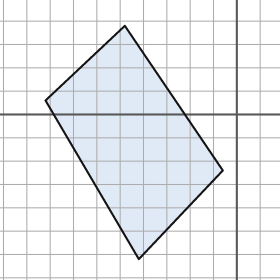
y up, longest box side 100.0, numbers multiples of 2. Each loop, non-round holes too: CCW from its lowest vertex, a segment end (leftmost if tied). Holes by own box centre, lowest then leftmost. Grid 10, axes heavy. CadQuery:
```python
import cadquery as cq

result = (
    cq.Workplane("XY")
    .moveTo(-42.0, -62.0)
    .lineTo(-6.0, -24.0)
    .lineTo(-48.0, 38.0)
    .lineTo(-82.0, 6.0)
    .close()
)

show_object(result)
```